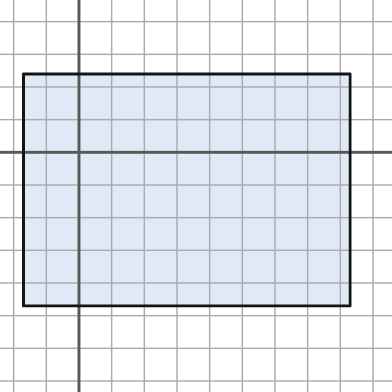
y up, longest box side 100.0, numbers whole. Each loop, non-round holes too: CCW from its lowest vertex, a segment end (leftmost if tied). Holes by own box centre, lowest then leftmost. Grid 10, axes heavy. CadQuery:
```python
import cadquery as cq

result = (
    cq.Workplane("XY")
    .moveTo(-17.0, -47.0)
    .lineTo(83.0, -47.0)
    .lineTo(83.0, 24.0)
    .lineTo(-17.0, 24.0)
    .close()
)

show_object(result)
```